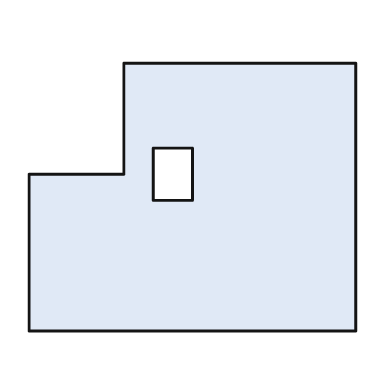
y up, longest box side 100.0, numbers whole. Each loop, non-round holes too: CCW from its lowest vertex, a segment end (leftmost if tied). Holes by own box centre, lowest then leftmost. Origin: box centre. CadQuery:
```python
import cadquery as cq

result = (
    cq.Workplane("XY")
    .moveTo(-50.0, -41.0)
    .lineTo(50.0, -41.0)
    .lineTo(50.0, 41.0)
    .lineTo(-21.0, 41.0)
    .lineTo(-21.0, 7.0)
    .lineTo(-50.0, 7.0)
    .close()
    .moveTo(-12.0, -1.0)
    .lineTo(0.0, -1.0)
    .lineTo(0.0, 15.0)
    .lineTo(-12.0, 15.0)
    .close()
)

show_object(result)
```